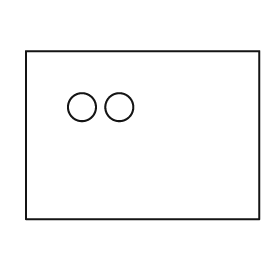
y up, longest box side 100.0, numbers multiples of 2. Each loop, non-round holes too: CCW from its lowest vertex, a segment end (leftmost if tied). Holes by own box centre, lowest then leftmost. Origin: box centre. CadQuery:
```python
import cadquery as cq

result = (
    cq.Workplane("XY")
    .moveTo(-50.0, -36.0)
    .lineTo(50.0, -36.0)
    .lineTo(50.0, 36.0)
    .lineTo(-50.0, 36.0)
    .close()
    .moveTo(-26.0, 12.0)
    .circle(6.0)
    .moveTo(-10.0, 12.0)
    .circle(6.0)
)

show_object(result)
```